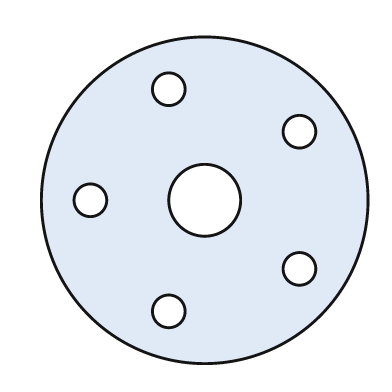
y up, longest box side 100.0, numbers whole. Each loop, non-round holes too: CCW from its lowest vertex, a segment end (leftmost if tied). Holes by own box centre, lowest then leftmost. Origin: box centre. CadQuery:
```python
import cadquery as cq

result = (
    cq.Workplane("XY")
    .moveTo(0.0, 0.0)
    .circle(50.0)
    .moveTo(-11.0, -34.0)
    .circle(5.0)
    .moveTo(29.0, -21.0)
    .circle(5.0)
    .moveTo(-35.0, 0.0)
    .circle(5.0)
    .moveTo(0.0, 0.0)
    .circle(11.0)
    .moveTo(29.0, 21.0)
    .circle(5.0)
    .moveTo(-11.0, 34.0)
    .circle(5.0)
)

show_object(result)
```